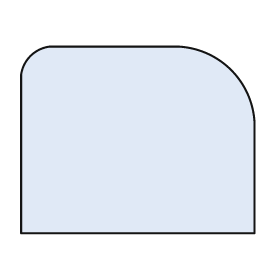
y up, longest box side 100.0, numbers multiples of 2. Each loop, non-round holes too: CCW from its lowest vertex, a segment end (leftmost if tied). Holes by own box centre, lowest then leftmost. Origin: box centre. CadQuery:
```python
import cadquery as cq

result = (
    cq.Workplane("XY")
    .moveTo(-50.0, -40.0)
    .lineTo(50.0, -40.0)
    .lineTo(50.0, 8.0)
    .threePointArc((40.0, 30.0), (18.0, 40.0))
    .lineTo(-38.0, 40.0)
    .threePointArc((-46.0, 36.0), (-50.0, 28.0))
    .close()
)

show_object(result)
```